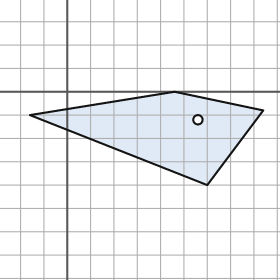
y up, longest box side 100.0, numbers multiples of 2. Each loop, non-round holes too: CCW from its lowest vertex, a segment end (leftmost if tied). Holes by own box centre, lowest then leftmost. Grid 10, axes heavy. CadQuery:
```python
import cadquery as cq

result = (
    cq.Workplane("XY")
    .moveTo(60.0, -40.0)
    .lineTo(84.0, -8.0)
    .lineTo(46.0, 0.0)
    .lineTo(-16.0, -10.0)
    .close()
    .moveTo(56.0, -12.0)
    .circle(2.0)
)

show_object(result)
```